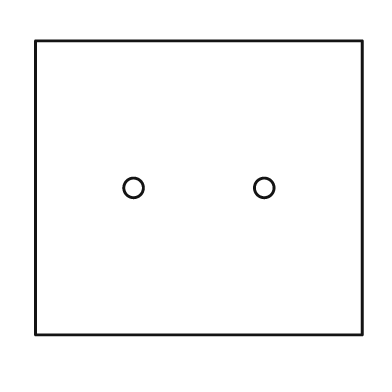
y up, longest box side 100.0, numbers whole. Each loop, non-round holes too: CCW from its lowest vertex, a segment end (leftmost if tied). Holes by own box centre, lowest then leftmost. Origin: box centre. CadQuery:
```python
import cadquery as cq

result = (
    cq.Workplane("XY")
    .moveTo(-50.0, -45.0)
    .lineTo(50.0, -45.0)
    .lineTo(50.0, 45.0)
    .lineTo(-50.0, 45.0)
    .close()
    .moveTo(-20.0, 0.0)
    .circle(3.0)
    .moveTo(20.0, 0.0)
    .circle(3.0)
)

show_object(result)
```